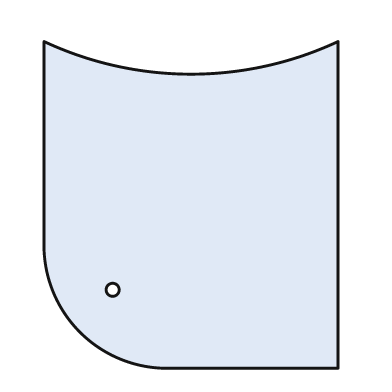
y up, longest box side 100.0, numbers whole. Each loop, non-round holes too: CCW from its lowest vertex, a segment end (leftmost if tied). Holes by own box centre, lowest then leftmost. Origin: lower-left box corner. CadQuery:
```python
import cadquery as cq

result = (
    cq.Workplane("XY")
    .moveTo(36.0, 0.0)
    .lineTo(90.0, 0.0)
    .lineTo(90.0, 100.0)
    .threePointArc((45.0, 90.0), (0.0, 100.0))
    .lineTo(0.0, 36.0)
    .threePointArc((11.0, 11.0), (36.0, 0.0))
    .close()
    .moveTo(21.0, 24.0)
    .circle(2.0)
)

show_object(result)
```